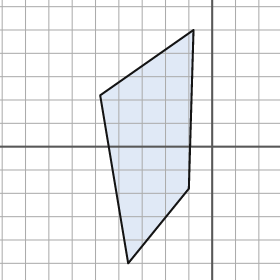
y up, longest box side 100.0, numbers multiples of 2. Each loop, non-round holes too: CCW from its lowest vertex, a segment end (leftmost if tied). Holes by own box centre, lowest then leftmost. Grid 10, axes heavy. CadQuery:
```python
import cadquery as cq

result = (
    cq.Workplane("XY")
    .moveTo(-36.0, -50.0)
    .lineTo(-10.0, -18.0)
    .lineTo(-8.0, 50.0)
    .lineTo(-48.0, 22.0)
    .close()
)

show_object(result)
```